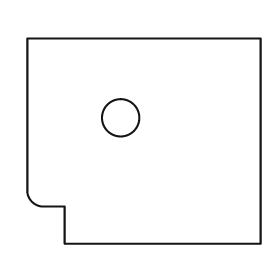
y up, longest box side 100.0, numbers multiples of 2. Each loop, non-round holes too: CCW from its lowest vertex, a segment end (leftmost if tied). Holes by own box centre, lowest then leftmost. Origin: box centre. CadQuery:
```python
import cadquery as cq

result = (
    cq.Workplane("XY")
    .moveTo(-34.0, -44.0)
    .lineTo(50.0, -44.0)
    .lineTo(50.0, 44.0)
    .lineTo(-50.0, 44.0)
    .lineTo(-50.0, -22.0)
    .threePointArc((-48.0, -26.0), (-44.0, -28.0))
    .lineTo(-34.0, -28.0)
    .close()
    .moveTo(-10.0, 10.0)
    .circle(8.0)
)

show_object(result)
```